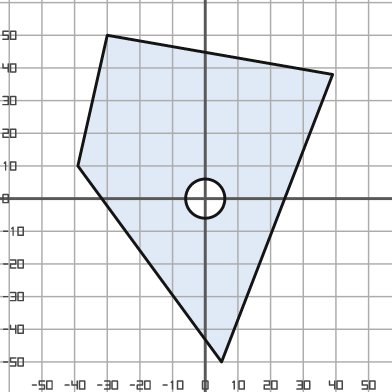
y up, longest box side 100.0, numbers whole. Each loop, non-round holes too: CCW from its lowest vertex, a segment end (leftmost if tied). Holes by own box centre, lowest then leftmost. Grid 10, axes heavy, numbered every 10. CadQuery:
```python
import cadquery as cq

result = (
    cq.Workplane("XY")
    .moveTo(5.0, -50.0)
    .lineTo(39.0, 38.0)
    .lineTo(-30.0, 50.0)
    .lineTo(-39.0, 10.0)
    .close()
    .moveTo(0.0, 0.0)
    .circle(6.0)
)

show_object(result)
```